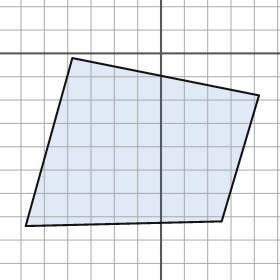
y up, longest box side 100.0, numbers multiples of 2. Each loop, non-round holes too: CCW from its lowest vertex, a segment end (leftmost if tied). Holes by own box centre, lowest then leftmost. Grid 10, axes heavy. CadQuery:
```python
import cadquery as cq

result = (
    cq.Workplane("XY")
    .moveTo(-58.0, -74.0)
    .lineTo(26.0, -72.0)
    .lineTo(42.0, -18.0)
    .lineTo(-38.0, -2.0)
    .close()
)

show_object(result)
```